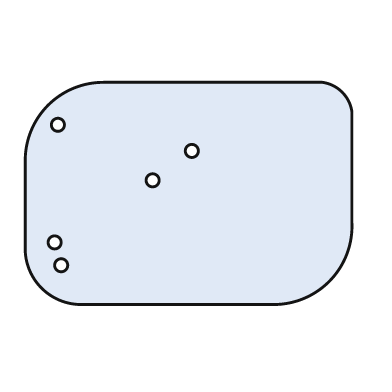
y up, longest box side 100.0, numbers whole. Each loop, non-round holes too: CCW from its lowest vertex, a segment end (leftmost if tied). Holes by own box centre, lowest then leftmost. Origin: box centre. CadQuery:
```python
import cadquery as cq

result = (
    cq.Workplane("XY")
    .moveTo(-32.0, -34.0)
    .lineTo(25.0, -34.0)
    .threePointArc((43.0, -27.0), (50.0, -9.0))
    .lineTo(50.0, 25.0)
    .threePointArc((47.0, 31.0), (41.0, 34.0))
    .lineTo(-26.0, 34.0)
    .threePointArc((-43.0, 27.0), (-50.0, 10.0))
    .lineTo(-50.0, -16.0)
    .threePointArc((-45.0, -29.0), (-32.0, -34.0))
    .close()
    .moveTo(-39.0, -22.0)
    .circle(2.0)
    .moveTo(-41.0, -15.0)
    .circle(2.0)
    .moveTo(-11.0, 4.0)
    .circle(2.0)
    .moveTo(1.0, 13.0)
    .circle(2.0)
    .moveTo(-40.0, 21.0)
    .circle(2.0)
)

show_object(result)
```